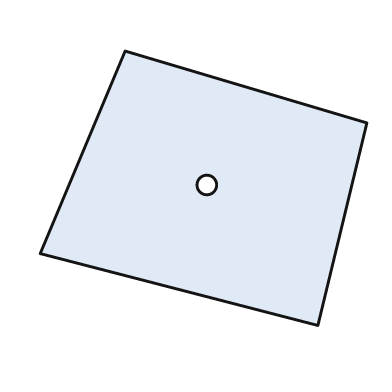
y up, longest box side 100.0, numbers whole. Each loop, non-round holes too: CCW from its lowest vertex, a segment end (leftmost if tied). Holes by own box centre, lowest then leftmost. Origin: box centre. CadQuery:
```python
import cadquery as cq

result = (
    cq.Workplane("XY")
    .moveTo(35.0, -42.0)
    .lineTo(50.0, 20.0)
    .lineTo(-24.0, 42.0)
    .lineTo(-50.0, -20.0)
    .close()
    .moveTo(1.0, 1.0)
    .circle(3.0)
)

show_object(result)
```